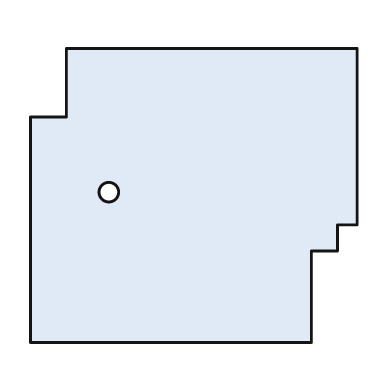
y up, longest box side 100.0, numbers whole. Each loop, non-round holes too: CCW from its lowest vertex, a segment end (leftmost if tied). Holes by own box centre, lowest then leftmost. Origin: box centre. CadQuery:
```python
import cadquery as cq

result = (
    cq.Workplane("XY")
    .moveTo(-50.0, -45.0)
    .lineTo(36.0, -45.0)
    .lineTo(36.0, -17.0)
    .lineTo(44.0, -17.0)
    .lineTo(44.0, -9.0)
    .lineTo(50.0, -9.0)
    .lineTo(50.0, 45.0)
    .lineTo(-39.0, 45.0)
    .lineTo(-39.0, 24.0)
    .lineTo(-50.0, 24.0)
    .close()
    .moveTo(-26.0, 1.0)
    .circle(3.0)
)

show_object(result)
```